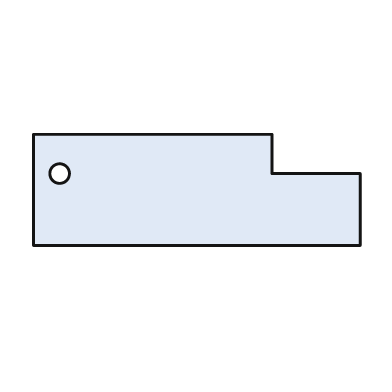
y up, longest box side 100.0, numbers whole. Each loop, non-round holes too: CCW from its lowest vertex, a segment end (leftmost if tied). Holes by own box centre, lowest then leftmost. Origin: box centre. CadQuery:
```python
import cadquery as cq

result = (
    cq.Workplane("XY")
    .moveTo(-50.0, -17.0)
    .lineTo(50.0, -17.0)
    .lineTo(50.0, 5.0)
    .lineTo(23.0, 5.0)
    .lineTo(23.0, 17.0)
    .lineTo(-50.0, 17.0)
    .close()
    .moveTo(-42.0, 5.0)
    .circle(3.0)
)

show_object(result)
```